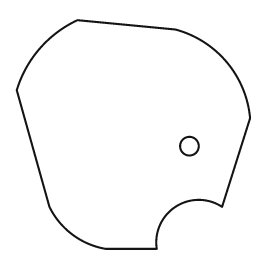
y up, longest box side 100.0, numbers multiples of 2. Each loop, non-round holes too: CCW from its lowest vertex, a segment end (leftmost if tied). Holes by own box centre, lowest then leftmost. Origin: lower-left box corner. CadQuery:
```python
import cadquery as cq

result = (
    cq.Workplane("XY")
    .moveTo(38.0, 0.0)
    .lineTo(60.0, 0.0)
    .threePointArc((68.0, 18.0), (88.0, 18.0))
    .lineTo(100.0, 56.0)
    .threePointArc((90.0, 80.0), (68.0, 94.0))
    .lineTo(26.0, 98.0)
    .threePointArc((10.0, 86.0), (0.0, 68.0))
    .lineTo(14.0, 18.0)
    .threePointArc((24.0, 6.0), (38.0, 0.0))
    .close()
    .moveTo(74.0, 44.0)
    .circle(4.0)
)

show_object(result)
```